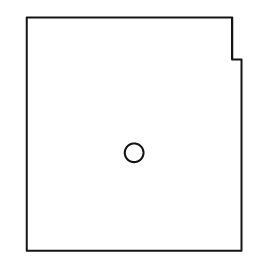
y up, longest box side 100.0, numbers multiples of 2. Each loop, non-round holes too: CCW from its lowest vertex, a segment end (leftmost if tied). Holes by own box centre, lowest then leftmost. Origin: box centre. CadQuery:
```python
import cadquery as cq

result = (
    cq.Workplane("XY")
    .moveTo(-46.0, -50.0)
    .lineTo(46.0, -50.0)
    .lineTo(46.0, 32.0)
    .lineTo(42.0, 32.0)
    .lineTo(42.0, 50.0)
    .lineTo(-46.0, 50.0)
    .close()
    .moveTo(0.0, -8.0)
    .circle(4.0)
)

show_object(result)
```